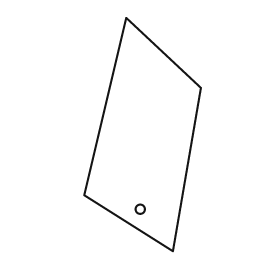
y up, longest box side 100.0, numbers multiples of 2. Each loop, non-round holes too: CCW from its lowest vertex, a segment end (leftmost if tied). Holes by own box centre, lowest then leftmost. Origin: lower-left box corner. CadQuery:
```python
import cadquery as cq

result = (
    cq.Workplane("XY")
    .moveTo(38.0, 0.0)
    .lineTo(50.0, 70.0)
    .lineTo(18.0, 100.0)
    .lineTo(0.0, 24.0)
    .close()
    .moveTo(24.0, 18.0)
    .circle(2.0)
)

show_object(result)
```